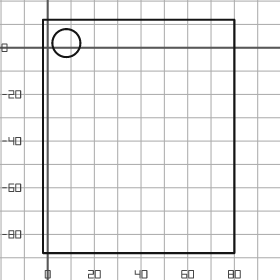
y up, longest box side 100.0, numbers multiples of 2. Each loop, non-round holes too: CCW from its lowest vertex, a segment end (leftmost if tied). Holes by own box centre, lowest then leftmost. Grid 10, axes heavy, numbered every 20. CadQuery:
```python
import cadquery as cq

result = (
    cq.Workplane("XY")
    .moveTo(-2.0, -88.0)
    .lineTo(80.0, -88.0)
    .lineTo(80.0, 12.0)
    .lineTo(-2.0, 12.0)
    .close()
    .moveTo(8.0, 2.0)
    .circle(6.0)
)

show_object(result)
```